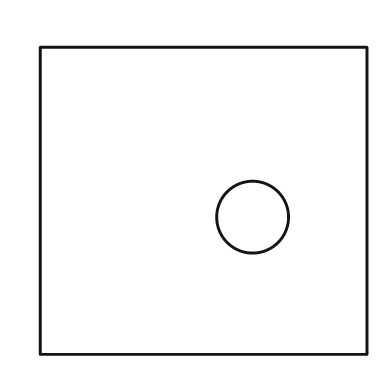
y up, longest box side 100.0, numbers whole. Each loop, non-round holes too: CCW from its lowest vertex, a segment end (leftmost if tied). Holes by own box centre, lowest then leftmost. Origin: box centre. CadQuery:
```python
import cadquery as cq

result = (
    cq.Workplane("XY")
    .moveTo(-50.0, -47.0)
    .lineTo(50.0, -47.0)
    .lineTo(50.0, 47.0)
    .lineTo(-50.0, 47.0)
    .close()
    .moveTo(15.0, -5.0)
    .circle(11.0)
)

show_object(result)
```